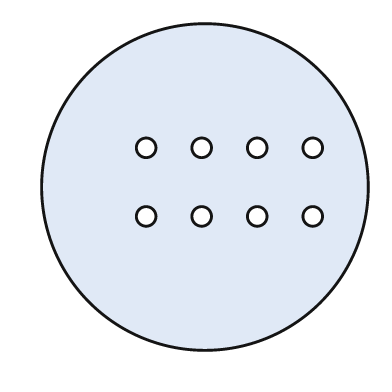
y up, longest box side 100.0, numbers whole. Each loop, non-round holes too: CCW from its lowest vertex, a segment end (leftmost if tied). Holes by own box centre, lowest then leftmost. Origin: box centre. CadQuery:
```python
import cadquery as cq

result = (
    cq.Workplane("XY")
    .moveTo(0.0, 0.0)
    .circle(50.0)
    .moveTo(-18.0, -9.0)
    .circle(3.0)
    .moveTo(-1.0, -9.0)
    .circle(3.0)
    .moveTo(16.0, -9.0)
    .circle(3.0)
    .moveTo(33.0, -9.0)
    .circle(3.0)
    .moveTo(-18.0, 12.0)
    .circle(3.0)
    .moveTo(-1.0, 12.0)
    .circle(3.0)
    .moveTo(16.0, 12.0)
    .circle(3.0)
    .moveTo(33.0, 12.0)
    .circle(3.0)
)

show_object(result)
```